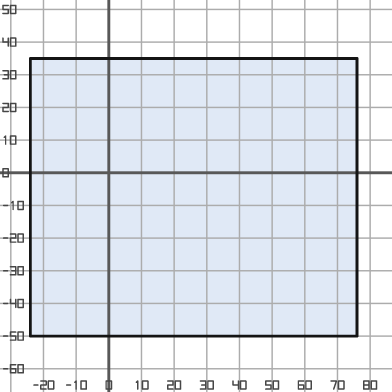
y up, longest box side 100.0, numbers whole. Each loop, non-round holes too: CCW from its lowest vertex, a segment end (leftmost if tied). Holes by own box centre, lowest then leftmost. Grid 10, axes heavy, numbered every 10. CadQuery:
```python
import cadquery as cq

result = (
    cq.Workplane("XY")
    .moveTo(-24.0, -50.0)
    .lineTo(76.0, -50.0)
    .lineTo(76.0, 35.0)
    .lineTo(-24.0, 35.0)
    .close()
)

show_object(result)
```